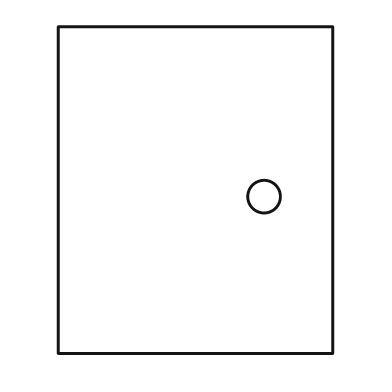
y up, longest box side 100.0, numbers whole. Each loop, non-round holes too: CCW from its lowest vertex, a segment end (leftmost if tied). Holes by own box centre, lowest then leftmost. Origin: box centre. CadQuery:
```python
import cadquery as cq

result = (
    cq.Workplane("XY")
    .moveTo(-42.0, -50.0)
    .lineTo(42.0, -50.0)
    .lineTo(42.0, 50.0)
    .lineTo(-42.0, 50.0)
    .close()
    .moveTo(21.0, -2.0)
    .circle(5.0)
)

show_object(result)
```